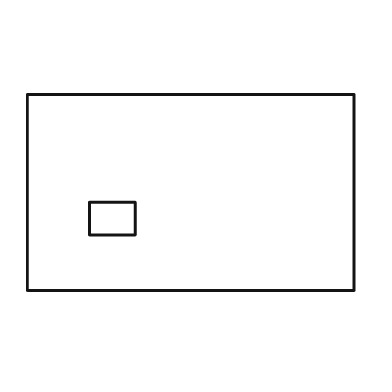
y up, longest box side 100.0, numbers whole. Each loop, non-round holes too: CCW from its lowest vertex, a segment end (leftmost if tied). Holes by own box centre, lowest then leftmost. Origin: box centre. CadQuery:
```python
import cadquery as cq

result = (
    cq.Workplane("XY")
    .moveTo(-50.0, -30.0)
    .lineTo(50.0, -30.0)
    .lineTo(50.0, 30.0)
    .lineTo(-50.0, 30.0)
    .close()
    .moveTo(-31.0, -13.0)
    .lineTo(-17.0, -13.0)
    .lineTo(-17.0, -3.0)
    .lineTo(-31.0, -3.0)
    .close()
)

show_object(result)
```